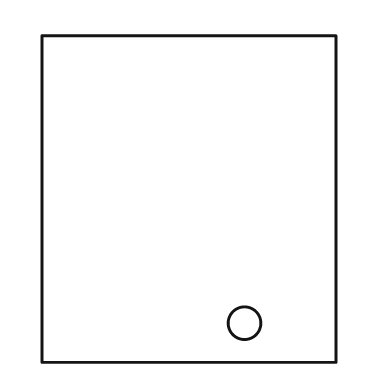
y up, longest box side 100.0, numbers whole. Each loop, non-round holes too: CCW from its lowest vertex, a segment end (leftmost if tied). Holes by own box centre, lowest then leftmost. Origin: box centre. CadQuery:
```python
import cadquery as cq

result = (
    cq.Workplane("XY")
    .moveTo(-45.0, -50.0)
    .lineTo(45.0, -50.0)
    .lineTo(45.0, 50.0)
    .lineTo(-45.0, 50.0)
    .close()
    .moveTo(17.0, -38.0)
    .circle(5.0)
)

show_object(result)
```